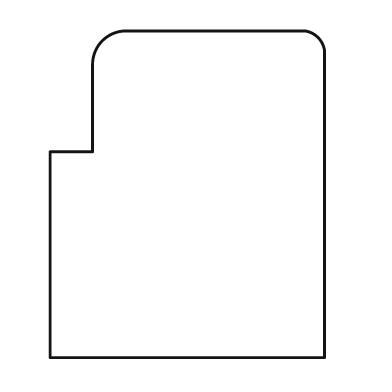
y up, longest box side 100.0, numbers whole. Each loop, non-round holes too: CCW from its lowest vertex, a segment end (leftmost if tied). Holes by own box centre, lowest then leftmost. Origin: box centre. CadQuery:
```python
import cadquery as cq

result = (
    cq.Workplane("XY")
    .moveTo(-42.0, -50.0)
    .lineTo(42.0, -50.0)
    .lineTo(42.0, 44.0)
    .threePointArc((40.0, 48.0), (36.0, 50.0))
    .lineTo(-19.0, 50.0)
    .threePointArc((-26.0, 47.0), (-29.0, 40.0))
    .lineTo(-29.0, 13.0)
    .lineTo(-42.0, 13.0)
    .close()
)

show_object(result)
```